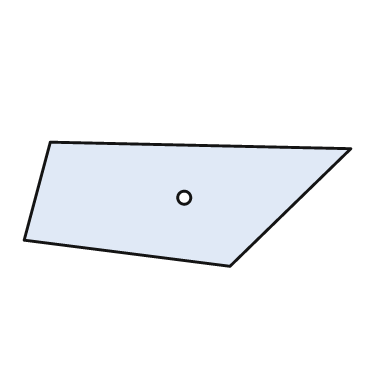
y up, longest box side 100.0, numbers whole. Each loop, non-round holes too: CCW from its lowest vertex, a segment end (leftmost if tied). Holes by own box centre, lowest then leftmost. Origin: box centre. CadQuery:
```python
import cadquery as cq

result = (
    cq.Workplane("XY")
    .moveTo(13.0, -19.0)
    .lineTo(50.0, 17.0)
    .lineTo(-42.0, 19.0)
    .lineTo(-50.0, -11.0)
    .close()
    .moveTo(-1.0, 2.0)
    .circle(2.0)
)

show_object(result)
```